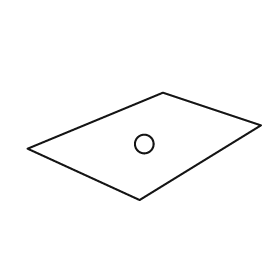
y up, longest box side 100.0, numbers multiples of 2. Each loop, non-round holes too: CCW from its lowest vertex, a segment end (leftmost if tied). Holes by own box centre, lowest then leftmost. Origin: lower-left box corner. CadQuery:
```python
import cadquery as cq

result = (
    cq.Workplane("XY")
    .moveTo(48.0, 0.0)
    .lineTo(100.0, 32.0)
    .lineTo(58.0, 46.0)
    .lineTo(0.0, 22.0)
    .close()
    .moveTo(50.0, 24.0)
    .circle(4.0)
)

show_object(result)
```